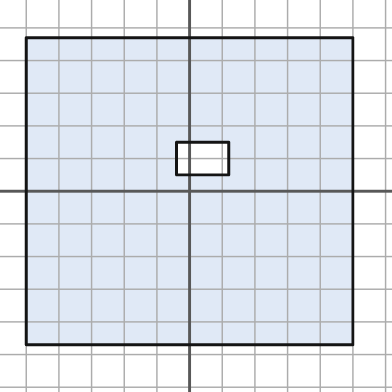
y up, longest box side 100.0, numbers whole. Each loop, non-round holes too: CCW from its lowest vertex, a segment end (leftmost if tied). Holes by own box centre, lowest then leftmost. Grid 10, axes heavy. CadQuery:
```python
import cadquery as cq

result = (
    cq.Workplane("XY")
    .moveTo(-50.0, -47.0)
    .lineTo(50.0, -47.0)
    .lineTo(50.0, 47.0)
    .lineTo(-50.0, 47.0)
    .close()
    .moveTo(-4.0, 5.0)
    .lineTo(12.0, 5.0)
    .lineTo(12.0, 15.0)
    .lineTo(-4.0, 15.0)
    .close()
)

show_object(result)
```